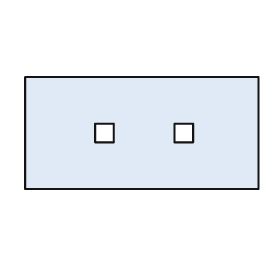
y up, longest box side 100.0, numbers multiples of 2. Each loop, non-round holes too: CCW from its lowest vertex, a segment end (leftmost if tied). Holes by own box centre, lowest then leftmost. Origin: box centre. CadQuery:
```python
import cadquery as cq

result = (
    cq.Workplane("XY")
    .moveTo(-50.0, -24.0)
    .lineTo(50.0, -24.0)
    .lineTo(50.0, 24.0)
    .lineTo(-50.0, 24.0)
    .close()
    .moveTo(-20.0, -4.0)
    .lineTo(-12.0, -4.0)
    .lineTo(-12.0, 4.0)
    .lineTo(-20.0, 4.0)
    .close()
    .moveTo(14.0, -4.0)
    .lineTo(22.0, -4.0)
    .lineTo(22.0, 4.0)
    .lineTo(14.0, 4.0)
    .close()
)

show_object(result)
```